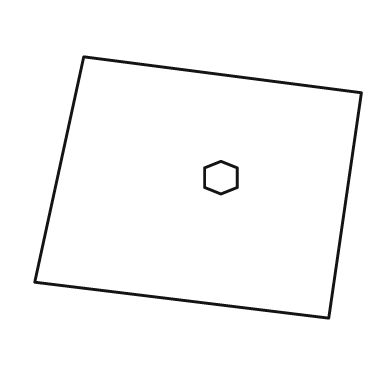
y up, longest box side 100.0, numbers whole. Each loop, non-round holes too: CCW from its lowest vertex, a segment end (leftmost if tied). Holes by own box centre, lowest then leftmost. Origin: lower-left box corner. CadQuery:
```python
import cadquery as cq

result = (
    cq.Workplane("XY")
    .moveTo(90.0, 0.0)
    .lineTo(100.0, 69.0)
    .lineTo(15.0, 80.0)
    .lineTo(0.0, 11.0)
    .close()
    .moveTo(57.0, 38.0)
    .lineTo(62.0, 40.0)
    .lineTo(62.0, 46.0)
    .lineTo(57.0, 48.0)
    .lineTo(52.0, 46.0)
    .lineTo(52.0, 40.0)
    .close()
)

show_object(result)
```